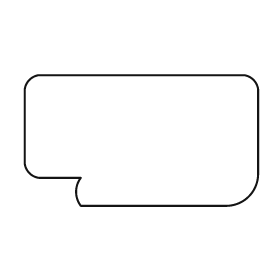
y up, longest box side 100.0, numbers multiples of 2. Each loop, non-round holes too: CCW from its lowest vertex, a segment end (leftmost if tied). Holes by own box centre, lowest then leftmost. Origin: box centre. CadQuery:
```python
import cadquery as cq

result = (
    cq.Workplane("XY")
    .moveTo(-26.0, -28.0)
    .lineTo(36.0, -28.0)
    .threePointArc((46.0, -24.0), (50.0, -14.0))
    .lineTo(50.0, 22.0)
    .threePointArc((48.0, 26.0), (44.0, 28.0))
    .lineTo(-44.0, 28.0)
    .threePointArc((-48.0, 26.0), (-50.0, 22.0))
    .lineTo(-50.0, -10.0)
    .threePointArc((-48.0, -14.0), (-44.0, -16.0))
    .lineTo(-26.0, -16.0)
    .threePointArc((-28.0, -22.0), (-26.0, -28.0))
    .close()
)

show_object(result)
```